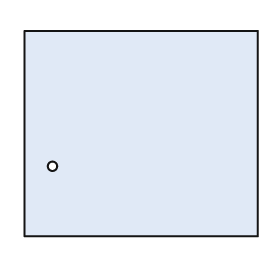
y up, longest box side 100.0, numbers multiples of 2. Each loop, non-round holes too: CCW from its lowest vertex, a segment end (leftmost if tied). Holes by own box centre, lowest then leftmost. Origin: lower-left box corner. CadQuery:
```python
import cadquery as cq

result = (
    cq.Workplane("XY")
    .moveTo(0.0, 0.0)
    .lineTo(100.0, 0.0)
    .lineTo(100.0, 88.0)
    .lineTo(0.0, 88.0)
    .close()
    .moveTo(12.0, 30.0)
    .circle(2.0)
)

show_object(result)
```